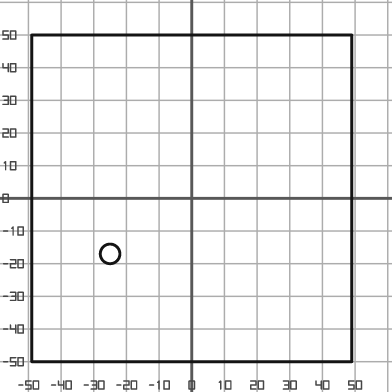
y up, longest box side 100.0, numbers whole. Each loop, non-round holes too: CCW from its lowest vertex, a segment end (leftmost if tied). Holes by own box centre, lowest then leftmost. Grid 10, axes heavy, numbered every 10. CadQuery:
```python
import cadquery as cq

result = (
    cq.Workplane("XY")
    .moveTo(-49.0, -50.0)
    .lineTo(49.0, -50.0)
    .lineTo(49.0, 50.0)
    .lineTo(-49.0, 50.0)
    .close()
    .moveTo(-25.0, -17.0)
    .circle(3.0)
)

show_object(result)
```